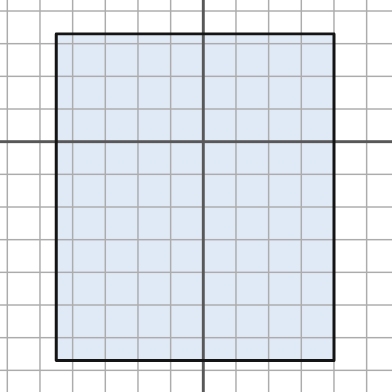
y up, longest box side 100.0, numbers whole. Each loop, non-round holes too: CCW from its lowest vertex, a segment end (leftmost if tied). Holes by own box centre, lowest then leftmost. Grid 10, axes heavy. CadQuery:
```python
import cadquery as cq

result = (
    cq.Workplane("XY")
    .moveTo(-45.0, -67.0)
    .lineTo(40.0, -67.0)
    .lineTo(40.0, 33.0)
    .lineTo(-45.0, 33.0)
    .close()
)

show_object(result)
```